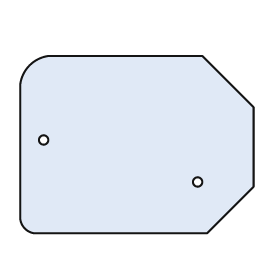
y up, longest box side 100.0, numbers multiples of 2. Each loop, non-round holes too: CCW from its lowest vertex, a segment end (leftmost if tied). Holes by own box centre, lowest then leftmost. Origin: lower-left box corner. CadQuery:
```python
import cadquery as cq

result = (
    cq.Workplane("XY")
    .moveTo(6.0, 0.0)
    .lineTo(80.0, 0.0)
    .lineTo(100.0, 20.0)
    .lineTo(100.0, 54.0)
    .lineTo(78.0, 76.0)
    .lineTo(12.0, 76.0)
    .threePointArc((4.0, 72.0), (0.0, 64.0))
    .lineTo(0.0, 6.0)
    .threePointArc((2.0, 2.0), (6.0, 0.0))
    .close()
    .moveTo(76.0, 22.0)
    .circle(2.0)
    .moveTo(10.0, 40.0)
    .circle(2.0)
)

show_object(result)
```